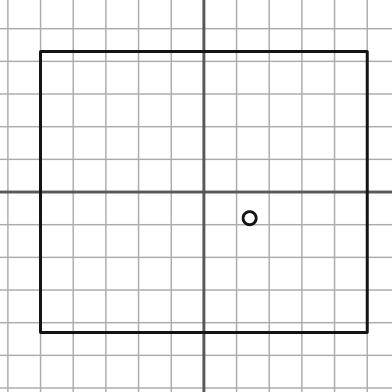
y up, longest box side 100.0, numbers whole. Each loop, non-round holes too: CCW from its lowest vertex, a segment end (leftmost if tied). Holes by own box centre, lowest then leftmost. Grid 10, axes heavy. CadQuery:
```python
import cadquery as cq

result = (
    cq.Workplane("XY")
    .moveTo(-50.0, -43.0)
    .lineTo(50.0, -43.0)
    .lineTo(50.0, 43.0)
    .lineTo(-50.0, 43.0)
    .close()
    .moveTo(14.0, -8.0)
    .circle(2.0)
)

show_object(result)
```